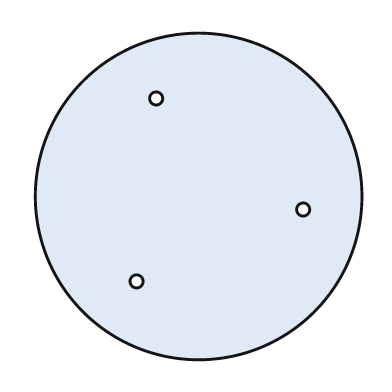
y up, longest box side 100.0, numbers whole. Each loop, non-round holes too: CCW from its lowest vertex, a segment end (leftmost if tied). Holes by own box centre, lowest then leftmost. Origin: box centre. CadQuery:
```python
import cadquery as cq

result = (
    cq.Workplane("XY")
    .moveTo(0.0, 0.0)
    .circle(50.0)
    .moveTo(-19.0, -26.0)
    .circle(2.0)
    .moveTo(32.0, -4.0)
    .circle(2.0)
    .moveTo(-13.0, 30.0)
    .circle(2.0)
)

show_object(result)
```